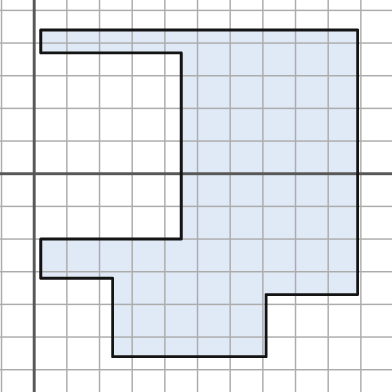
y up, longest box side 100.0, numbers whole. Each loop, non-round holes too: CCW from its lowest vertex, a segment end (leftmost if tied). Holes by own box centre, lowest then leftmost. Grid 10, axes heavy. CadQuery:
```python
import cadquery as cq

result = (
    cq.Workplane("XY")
    .moveTo(24.0, -56.0)
    .lineTo(71.0, -56.0)
    .lineTo(71.0, -37.0)
    .lineTo(99.0, -37.0)
    .lineTo(99.0, 44.0)
    .lineTo(2.0, 44.0)
    .lineTo(2.0, 37.0)
    .lineTo(45.0, 37.0)
    .lineTo(45.0, -20.0)
    .lineTo(2.0, -20.0)
    .lineTo(2.0, -32.0)
    .lineTo(24.0, -32.0)
    .close()
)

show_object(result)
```